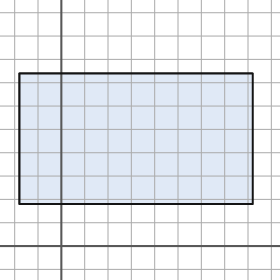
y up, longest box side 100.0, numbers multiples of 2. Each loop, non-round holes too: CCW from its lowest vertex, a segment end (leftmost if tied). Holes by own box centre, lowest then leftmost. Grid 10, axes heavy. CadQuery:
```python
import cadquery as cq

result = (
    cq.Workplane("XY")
    .moveTo(-18.0, 18.0)
    .lineTo(82.0, 18.0)
    .lineTo(82.0, 74.0)
    .lineTo(-18.0, 74.0)
    .close()
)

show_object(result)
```